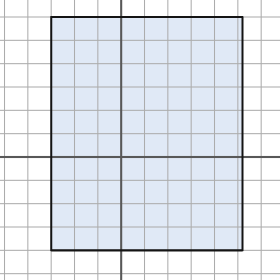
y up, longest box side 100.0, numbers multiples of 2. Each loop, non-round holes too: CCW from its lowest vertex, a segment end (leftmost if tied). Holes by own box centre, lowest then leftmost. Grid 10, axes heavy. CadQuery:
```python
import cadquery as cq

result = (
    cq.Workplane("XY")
    .moveTo(-30.0, -40.0)
    .lineTo(52.0, -40.0)
    .lineTo(52.0, 60.0)
    .lineTo(-30.0, 60.0)
    .close()
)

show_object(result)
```